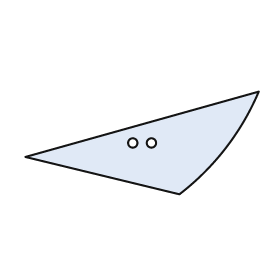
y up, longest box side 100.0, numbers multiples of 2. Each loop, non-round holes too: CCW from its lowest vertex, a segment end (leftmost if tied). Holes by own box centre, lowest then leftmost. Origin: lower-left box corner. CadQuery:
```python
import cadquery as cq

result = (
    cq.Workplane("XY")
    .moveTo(66.0, 0.0)
    .threePointArc((86.0, 20.0), (100.0, 44.0))
    .lineTo(0.0, 16.0)
    .close()
    .moveTo(46.0, 22.0)
    .circle(2.0)
    .moveTo(54.0, 22.0)
    .circle(2.0)
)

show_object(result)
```